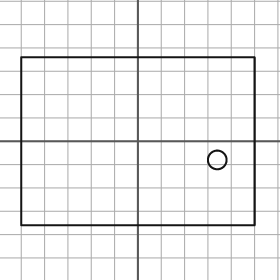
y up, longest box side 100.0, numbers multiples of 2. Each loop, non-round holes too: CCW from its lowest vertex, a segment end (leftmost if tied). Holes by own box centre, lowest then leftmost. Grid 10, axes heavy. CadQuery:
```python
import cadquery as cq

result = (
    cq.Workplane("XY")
    .moveTo(-50.0, -36.0)
    .lineTo(50.0, -36.0)
    .lineTo(50.0, 36.0)
    .lineTo(-50.0, 36.0)
    .close()
    .moveTo(34.0, -8.0)
    .circle(4.0)
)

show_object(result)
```